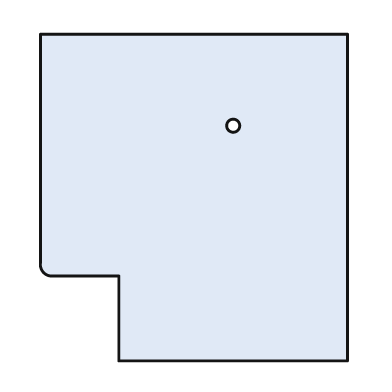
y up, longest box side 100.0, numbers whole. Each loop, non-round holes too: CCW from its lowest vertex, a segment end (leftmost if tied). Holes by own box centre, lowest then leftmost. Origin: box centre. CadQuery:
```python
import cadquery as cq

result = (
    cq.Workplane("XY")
    .moveTo(-23.0, -50.0)
    .lineTo(47.0, -50.0)
    .lineTo(47.0, 50.0)
    .lineTo(-47.0, 50.0)
    .lineTo(-47.0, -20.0)
    .threePointArc((-46.0, -23.0), (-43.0, -24.0))
    .lineTo(-23.0, -24.0)
    .close()
    .moveTo(12.0, 22.0)
    .circle(2.0)
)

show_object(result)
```